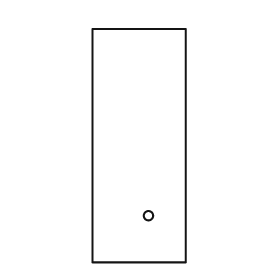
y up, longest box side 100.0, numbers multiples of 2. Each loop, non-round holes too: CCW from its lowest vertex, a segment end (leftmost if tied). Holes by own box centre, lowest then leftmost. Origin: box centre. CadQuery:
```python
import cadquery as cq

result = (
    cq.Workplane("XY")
    .moveTo(-20.0, -50.0)
    .lineTo(20.0, -50.0)
    .lineTo(20.0, 50.0)
    .lineTo(-20.0, 50.0)
    .close()
    .moveTo(4.0, -30.0)
    .circle(2.0)
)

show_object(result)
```